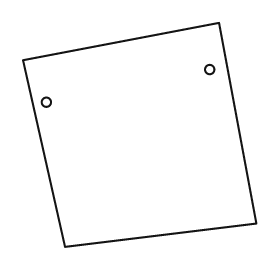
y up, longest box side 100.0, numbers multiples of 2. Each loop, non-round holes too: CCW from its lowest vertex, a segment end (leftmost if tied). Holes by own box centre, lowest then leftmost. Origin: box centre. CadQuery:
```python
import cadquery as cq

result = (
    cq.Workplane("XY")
    .moveTo(-32.0, -48.0)
    .lineTo(50.0, -38.0)
    .lineTo(34.0, 48.0)
    .lineTo(-50.0, 32.0)
    .close()
    .moveTo(-40.0, 14.0)
    .circle(2.0)
    .moveTo(30.0, 28.0)
    .circle(2.0)
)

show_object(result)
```